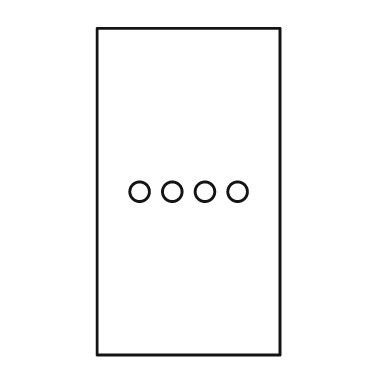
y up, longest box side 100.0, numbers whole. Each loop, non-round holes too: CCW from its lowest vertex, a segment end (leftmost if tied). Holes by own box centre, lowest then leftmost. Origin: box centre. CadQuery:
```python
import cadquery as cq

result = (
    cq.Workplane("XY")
    .moveTo(-28.0, -50.0)
    .lineTo(28.0, -50.0)
    .lineTo(28.0, 50.0)
    .lineTo(-28.0, 50.0)
    .close()
    .moveTo(-15.0, 0.0)
    .circle(3.0)
    .moveTo(-5.0, 0.0)
    .circle(3.0)
    .moveTo(5.0, 0.0)
    .circle(3.0)
    .moveTo(15.0, 0.0)
    .circle(3.0)
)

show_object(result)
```